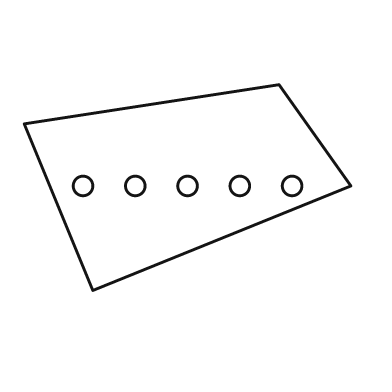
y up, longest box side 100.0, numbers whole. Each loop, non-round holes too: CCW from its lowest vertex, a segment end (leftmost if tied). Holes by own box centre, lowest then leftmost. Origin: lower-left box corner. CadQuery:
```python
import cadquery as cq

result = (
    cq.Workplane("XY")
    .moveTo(21.0, 0.0)
    .lineTo(100.0, 32.0)
    .lineTo(78.0, 63.0)
    .lineTo(0.0, 51.0)
    .close()
    .moveTo(18.0, 32.0)
    .circle(3.0)
    .moveTo(34.0, 32.0)
    .circle(3.0)
    .moveTo(50.0, 32.0)
    .circle(3.0)
    .moveTo(66.0, 32.0)
    .circle(3.0)
    .moveTo(82.0, 32.0)
    .circle(3.0)
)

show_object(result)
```